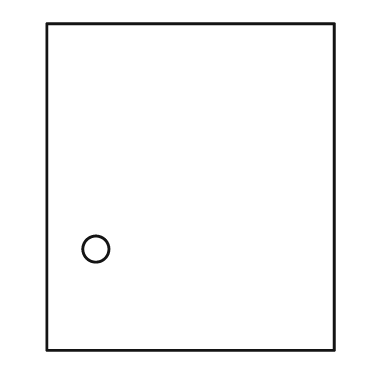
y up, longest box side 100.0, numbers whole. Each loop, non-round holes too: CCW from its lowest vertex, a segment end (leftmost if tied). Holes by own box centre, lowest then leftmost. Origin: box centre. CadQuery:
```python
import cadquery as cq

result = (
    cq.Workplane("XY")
    .moveTo(-44.0, -50.0)
    .lineTo(44.0, -50.0)
    .lineTo(44.0, 50.0)
    .lineTo(-44.0, 50.0)
    .close()
    .moveTo(-29.0, -19.0)
    .circle(4.0)
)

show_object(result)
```